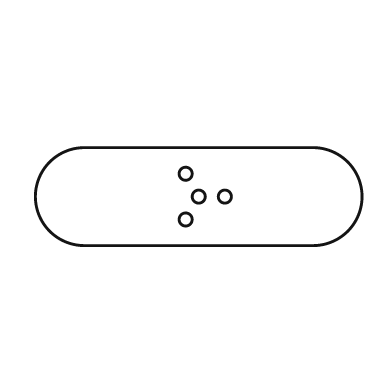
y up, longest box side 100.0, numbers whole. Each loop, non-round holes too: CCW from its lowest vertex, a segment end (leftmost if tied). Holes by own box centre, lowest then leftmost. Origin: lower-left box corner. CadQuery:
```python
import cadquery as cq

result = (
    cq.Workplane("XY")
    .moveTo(15.0, 0.0)
    .lineTo(85.0, 0.0)
    .threePointArc((100.0, 15.0), (85.0, 30.0))
    .lineTo(15.0, 30.0)
    .threePointArc((0.0, 15.0), (15.0, 0.0))
    .close()
    .moveTo(46.0, 8.0)
    .circle(2.0)
    .moveTo(50.0, 15.0)
    .circle(2.0)
    .moveTo(58.0, 15.0)
    .circle(2.0)
    .moveTo(46.0, 22.0)
    .circle(2.0)
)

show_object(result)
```